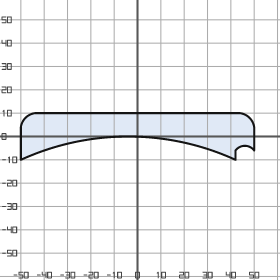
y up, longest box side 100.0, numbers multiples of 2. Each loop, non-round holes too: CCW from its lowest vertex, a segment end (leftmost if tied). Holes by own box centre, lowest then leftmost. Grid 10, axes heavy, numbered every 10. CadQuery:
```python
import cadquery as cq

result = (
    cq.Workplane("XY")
    .moveTo(-50.0, -10.0)
    .threePointArc((-4.0, 0.0), (42.0, -10.0))
    .lineTo(42.0, -6.0)
    .threePointArc((46.0, -4.0), (50.0, -6.0))
    .lineTo(50.0, 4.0)
    .threePointArc((48.0, 8.0), (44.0, 10.0))
    .lineTo(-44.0, 10.0)
    .threePointArc((-48.0, 8.0), (-50.0, 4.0))
    .close()
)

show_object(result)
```